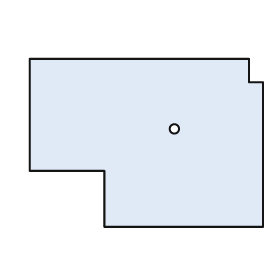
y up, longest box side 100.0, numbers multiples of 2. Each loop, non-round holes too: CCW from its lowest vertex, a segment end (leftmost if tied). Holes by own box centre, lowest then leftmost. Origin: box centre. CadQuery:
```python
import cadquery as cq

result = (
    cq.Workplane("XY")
    .moveTo(-18.0, -36.0)
    .lineTo(50.0, -36.0)
    .lineTo(50.0, 26.0)
    .lineTo(44.0, 26.0)
    .lineTo(44.0, 36.0)
    .lineTo(-50.0, 36.0)
    .lineTo(-50.0, -12.0)
    .lineTo(-18.0, -12.0)
    .close()
    .moveTo(12.0, 6.0)
    .circle(2.0)
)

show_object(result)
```